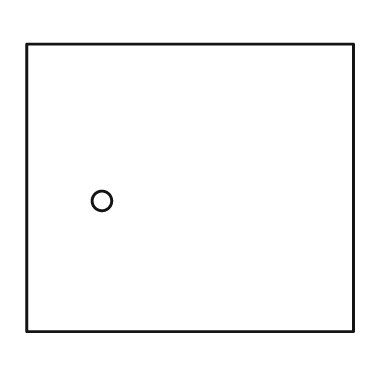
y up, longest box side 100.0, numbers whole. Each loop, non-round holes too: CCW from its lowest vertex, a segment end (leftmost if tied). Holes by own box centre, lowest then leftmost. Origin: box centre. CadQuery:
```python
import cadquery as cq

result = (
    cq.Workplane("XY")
    .moveTo(-50.0, -44.0)
    .lineTo(50.0, -44.0)
    .lineTo(50.0, 44.0)
    .lineTo(-50.0, 44.0)
    .close()
    .moveTo(-27.0, -4.0)
    .circle(3.0)
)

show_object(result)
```